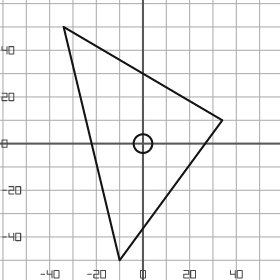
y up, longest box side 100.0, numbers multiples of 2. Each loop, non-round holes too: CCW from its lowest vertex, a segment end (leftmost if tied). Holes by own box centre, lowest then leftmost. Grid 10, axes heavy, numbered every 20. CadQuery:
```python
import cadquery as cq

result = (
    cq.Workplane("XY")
    .moveTo(-10.0, -50.0)
    .lineTo(34.0, 10.0)
    .lineTo(-34.0, 50.0)
    .close()
    .moveTo(0.0, 0.0)
    .circle(4.0)
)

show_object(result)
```